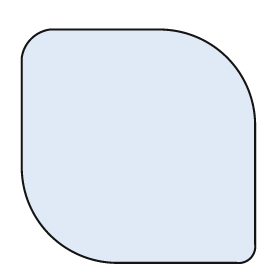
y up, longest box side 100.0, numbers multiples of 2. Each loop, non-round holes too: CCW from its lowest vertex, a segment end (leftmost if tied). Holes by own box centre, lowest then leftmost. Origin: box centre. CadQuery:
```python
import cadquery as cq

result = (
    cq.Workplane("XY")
    .moveTo(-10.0, -50.0)
    .lineTo(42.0, -50.0)
    .threePointArc((48.0, -48.0), (50.0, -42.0))
    .lineTo(50.0, 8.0)
    .threePointArc((38.0, 38.0), (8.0, 50.0))
    .lineTo(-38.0, 50.0)
    .threePointArc((-46.0, 46.0), (-50.0, 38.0))
    .lineTo(-50.0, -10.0)
    .threePointArc((-38.0, -38.0), (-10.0, -50.0))
    .close()
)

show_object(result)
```